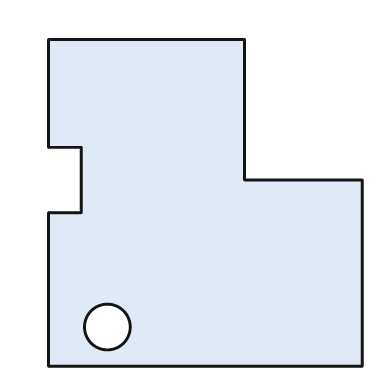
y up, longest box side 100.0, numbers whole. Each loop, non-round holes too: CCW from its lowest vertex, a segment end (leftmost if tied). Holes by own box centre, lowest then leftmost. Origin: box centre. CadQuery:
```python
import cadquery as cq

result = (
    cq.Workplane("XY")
    .moveTo(-48.0, -50.0)
    .lineTo(48.0, -50.0)
    .lineTo(48.0, 7.0)
    .lineTo(12.0, 7.0)
    .lineTo(12.0, 50.0)
    .lineTo(-48.0, 50.0)
    .lineTo(-48.0, 17.0)
    .lineTo(-38.0, 17.0)
    .lineTo(-38.0, -3.0)
    .lineTo(-48.0, -3.0)
    .close()
    .moveTo(-30.0, -38.0)
    .circle(7.0)
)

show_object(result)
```